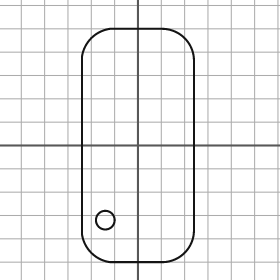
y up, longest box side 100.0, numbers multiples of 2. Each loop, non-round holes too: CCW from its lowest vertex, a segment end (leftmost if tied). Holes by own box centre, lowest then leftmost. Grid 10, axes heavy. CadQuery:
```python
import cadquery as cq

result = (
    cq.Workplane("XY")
    .moveTo(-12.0, -50.0)
    .lineTo(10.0, -50.0)
    .threePointArc((20.0, -46.0), (24.0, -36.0))
    .lineTo(24.0, 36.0)
    .threePointArc((20.0, 46.0), (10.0, 50.0))
    .lineTo(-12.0, 50.0)
    .threePointArc((-20.0, 46.0), (-24.0, 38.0))
    .lineTo(-24.0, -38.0)
    .threePointArc((-20.0, -46.0), (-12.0, -50.0))
    .close()
    .moveTo(-14.0, -32.0)
    .circle(4.0)
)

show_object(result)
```